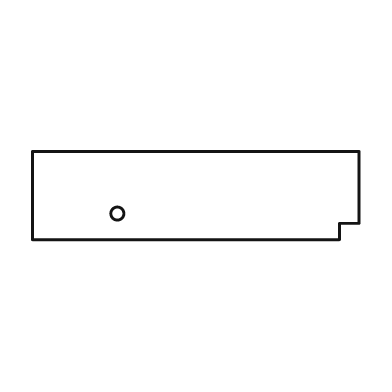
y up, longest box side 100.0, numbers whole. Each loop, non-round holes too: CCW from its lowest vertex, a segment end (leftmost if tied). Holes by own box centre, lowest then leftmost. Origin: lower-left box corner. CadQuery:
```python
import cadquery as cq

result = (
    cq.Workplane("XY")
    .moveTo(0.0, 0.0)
    .lineTo(94.0, 0.0)
    .lineTo(94.0, 5.0)
    .lineTo(100.0, 5.0)
    .lineTo(100.0, 27.0)
    .lineTo(0.0, 27.0)
    .close()
    .moveTo(26.0, 8.0)
    .circle(2.0)
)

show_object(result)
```